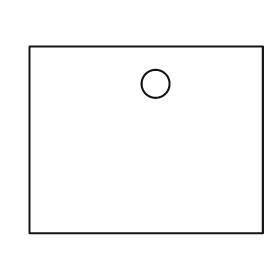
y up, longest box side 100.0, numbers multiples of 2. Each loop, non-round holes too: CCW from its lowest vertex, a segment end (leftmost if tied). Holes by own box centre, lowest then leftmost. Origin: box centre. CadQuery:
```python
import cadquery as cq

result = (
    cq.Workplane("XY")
    .moveTo(-50.0, -40.0)
    .lineTo(50.0, -40.0)
    .lineTo(50.0, 40.0)
    .lineTo(-50.0, 40.0)
    .close()
    .moveTo(4.0, 24.0)
    .circle(6.0)
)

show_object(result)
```